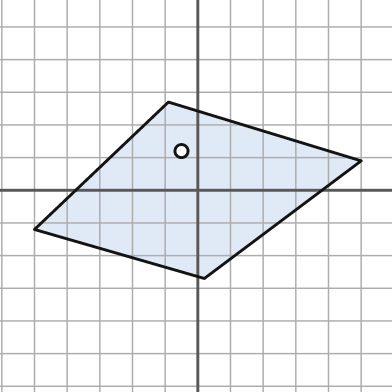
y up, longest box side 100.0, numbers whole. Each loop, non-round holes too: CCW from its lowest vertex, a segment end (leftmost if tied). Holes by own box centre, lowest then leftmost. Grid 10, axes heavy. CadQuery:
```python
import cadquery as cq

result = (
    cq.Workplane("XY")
    .moveTo(2.0, -27.0)
    .lineTo(50.0, 9.0)
    .lineTo(-9.0, 27.0)
    .lineTo(-50.0, -12.0)
    .close()
    .moveTo(-5.0, 12.0)
    .circle(2.0)
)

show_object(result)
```